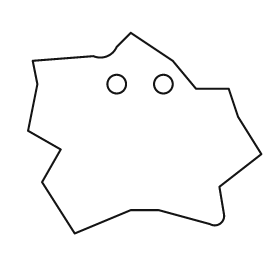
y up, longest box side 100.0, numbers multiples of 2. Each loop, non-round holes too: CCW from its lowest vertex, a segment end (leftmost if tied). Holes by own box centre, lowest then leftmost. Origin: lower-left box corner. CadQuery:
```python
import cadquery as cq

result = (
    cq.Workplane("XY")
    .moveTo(20.0, 0.0)
    .lineTo(44.0, 10.0)
    .lineTo(56.0, 10.0)
    .lineTo(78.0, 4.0)
    .threePointArc((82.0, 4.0), (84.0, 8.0))
    .lineTo(82.0, 20.0)
    .lineTo(100.0, 34.0)
    .lineTo(90.0, 50.0)
    .lineTo(86.0, 62.0)
    .lineTo(72.0, 62.0)
    .lineTo(62.0, 74.0)
    .lineTo(44.0, 86.0)
    .lineTo(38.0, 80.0)
    .threePointArc((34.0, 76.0), (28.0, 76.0))
    .lineTo(2.0, 74.0)
    .lineTo(4.0, 64.0)
    .lineTo(0.0, 44.0)
    .lineTo(14.0, 36.0)
    .lineTo(6.0, 22.0)
    .close()
    .moveTo(38.0, 64.0)
    .circle(4.0)
    .moveTo(58.0, 64.0)
    .circle(4.0)
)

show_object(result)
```